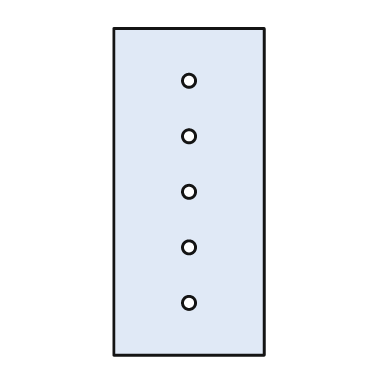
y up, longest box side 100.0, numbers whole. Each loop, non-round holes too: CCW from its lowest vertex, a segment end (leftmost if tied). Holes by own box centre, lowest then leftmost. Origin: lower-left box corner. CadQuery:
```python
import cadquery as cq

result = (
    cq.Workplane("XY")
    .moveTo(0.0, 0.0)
    .lineTo(46.0, 0.0)
    .lineTo(46.0, 100.0)
    .lineTo(0.0, 100.0)
    .close()
    .moveTo(23.0, 16.0)
    .circle(2.0)
    .moveTo(23.0, 33.0)
    .circle(2.0)
    .moveTo(23.0, 50.0)
    .circle(2.0)
    .moveTo(23.0, 67.0)
    .circle(2.0)
    .moveTo(23.0, 84.0)
    .circle(2.0)
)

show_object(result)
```